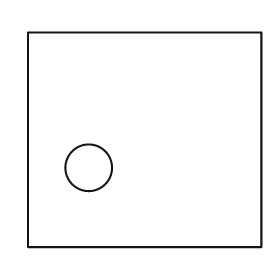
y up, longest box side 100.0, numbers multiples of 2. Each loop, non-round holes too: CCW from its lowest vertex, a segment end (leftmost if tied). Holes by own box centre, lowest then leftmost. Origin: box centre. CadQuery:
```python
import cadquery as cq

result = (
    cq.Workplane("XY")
    .moveTo(-50.0, -46.0)
    .lineTo(50.0, -46.0)
    .lineTo(50.0, 46.0)
    .lineTo(-50.0, 46.0)
    .close()
    .moveTo(-24.0, -12.0)
    .circle(10.0)
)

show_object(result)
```